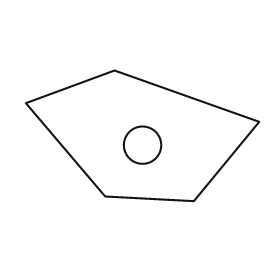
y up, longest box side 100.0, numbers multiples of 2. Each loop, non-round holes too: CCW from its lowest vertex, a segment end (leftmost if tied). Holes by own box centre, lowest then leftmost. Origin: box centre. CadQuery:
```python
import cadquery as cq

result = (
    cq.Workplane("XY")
    .moveTo(22.0, -28.0)
    .lineTo(50.0, 6.0)
    .lineTo(-12.0, 28.0)
    .lineTo(-50.0, 14.0)
    .lineTo(-16.0, -26.0)
    .close()
    .moveTo(0.0, -4.0)
    .circle(8.0)
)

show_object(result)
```